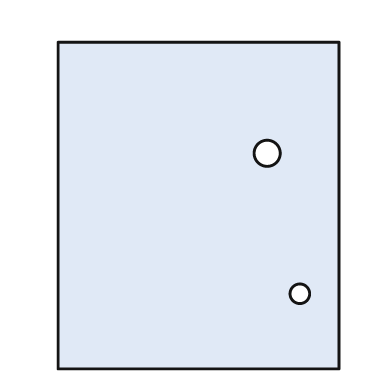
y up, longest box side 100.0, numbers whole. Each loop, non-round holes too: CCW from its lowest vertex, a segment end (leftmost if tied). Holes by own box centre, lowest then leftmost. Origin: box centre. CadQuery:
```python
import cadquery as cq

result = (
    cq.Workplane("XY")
    .moveTo(-43.0, -50.0)
    .lineTo(43.0, -50.0)
    .lineTo(43.0, 50.0)
    .lineTo(-43.0, 50.0)
    .close()
    .moveTo(31.0, -27.0)
    .circle(3.0)
    .moveTo(21.0, 16.0)
    .circle(4.0)
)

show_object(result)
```